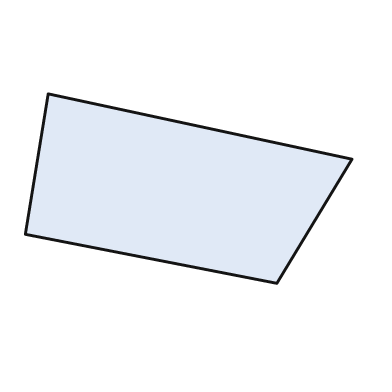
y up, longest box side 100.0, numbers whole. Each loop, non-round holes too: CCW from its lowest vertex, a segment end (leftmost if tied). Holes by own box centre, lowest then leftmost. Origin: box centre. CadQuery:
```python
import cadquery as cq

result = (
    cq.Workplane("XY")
    .moveTo(27.0, -29.0)
    .lineTo(50.0, 9.0)
    .lineTo(-43.0, 29.0)
    .lineTo(-50.0, -14.0)
    .close()
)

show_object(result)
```